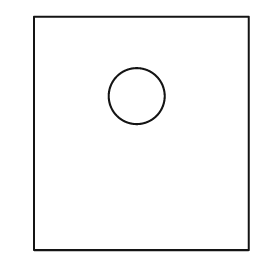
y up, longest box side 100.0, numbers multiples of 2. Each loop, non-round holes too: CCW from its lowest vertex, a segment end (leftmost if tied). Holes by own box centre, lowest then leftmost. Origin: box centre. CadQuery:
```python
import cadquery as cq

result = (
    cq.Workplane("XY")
    .moveTo(-46.0, -50.0)
    .lineTo(46.0, -50.0)
    .lineTo(46.0, 50.0)
    .lineTo(-46.0, 50.0)
    .close()
    .moveTo(-2.0, 16.0)
    .circle(12.0)
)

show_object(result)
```